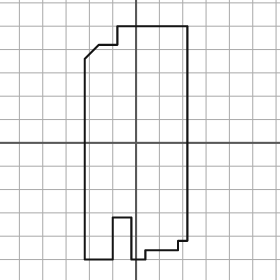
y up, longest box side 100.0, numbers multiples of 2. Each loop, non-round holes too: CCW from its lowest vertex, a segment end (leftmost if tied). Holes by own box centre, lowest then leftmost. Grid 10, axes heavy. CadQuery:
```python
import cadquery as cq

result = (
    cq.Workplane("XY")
    .moveTo(-22.0, -50.0)
    .lineTo(-10.0, -50.0)
    .lineTo(-10.0, -32.0)
    .lineTo(-2.0, -32.0)
    .lineTo(-2.0, -50.0)
    .lineTo(4.0, -50.0)
    .lineTo(4.0, -46.0)
    .lineTo(18.0, -46.0)
    .lineTo(18.0, -42.0)
    .lineTo(22.0, -42.0)
    .lineTo(22.0, 50.0)
    .lineTo(-8.0, 50.0)
    .lineTo(-8.0, 42.0)
    .lineTo(-16.0, 42.0)
    .lineTo(-22.0, 36.0)
    .close()
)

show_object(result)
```